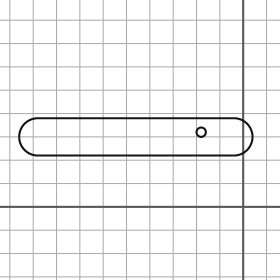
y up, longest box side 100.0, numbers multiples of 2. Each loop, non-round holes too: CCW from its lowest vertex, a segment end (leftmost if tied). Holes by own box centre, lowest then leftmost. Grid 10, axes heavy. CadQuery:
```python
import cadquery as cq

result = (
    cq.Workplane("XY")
    .moveTo(-88.0, 22.0)
    .lineTo(-4.0, 22.0)
    .threePointArc((4.0, 30.0), (-4.0, 38.0))
    .lineTo(-88.0, 38.0)
    .threePointArc((-96.0, 30.0), (-88.0, 22.0))
    .close()
    .moveTo(-18.0, 32.0)
    .circle(2.0)
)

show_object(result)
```